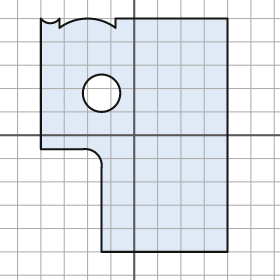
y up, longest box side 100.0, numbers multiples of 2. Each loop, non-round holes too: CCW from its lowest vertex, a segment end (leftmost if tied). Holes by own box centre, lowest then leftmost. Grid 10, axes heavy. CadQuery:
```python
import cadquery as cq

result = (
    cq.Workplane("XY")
    .moveTo(-14.0, -50.0)
    .lineTo(40.0, -50.0)
    .lineTo(40.0, 50.0)
    .lineTo(-8.0, 50.0)
    .lineTo(-8.0, 46.0)
    .threePointArc((-20.0, 50.0), (-32.0, 46.0))
    .lineTo(-32.0, 50.0)
    .threePointArc((-36.0, 48.0), (-40.0, 50.0))
    .lineTo(-40.0, -6.0)
    .lineTo(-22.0, -6.0)
    .threePointArc((-16.0, -8.0), (-14.0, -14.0))
    .close()
    .moveTo(-14.0, 18.0)
    .circle(8.0)
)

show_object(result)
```